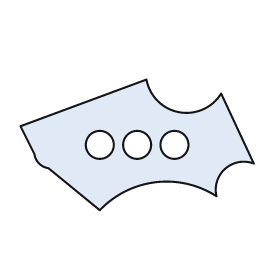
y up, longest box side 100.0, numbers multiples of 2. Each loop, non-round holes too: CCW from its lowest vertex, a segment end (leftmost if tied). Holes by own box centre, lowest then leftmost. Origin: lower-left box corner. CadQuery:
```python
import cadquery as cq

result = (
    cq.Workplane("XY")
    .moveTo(34.0, 0.0)
    .threePointArc((58.0, 12.0), (84.0, 6.0))
    .threePointArc((88.0, 18.0), (100.0, 20.0))
    .lineTo(86.0, 50.0)
    .threePointArc((68.0, 42.0), (54.0, 56.0))
    .lineTo(0.0, 36.0)
    .lineTo(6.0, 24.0)
    .threePointArc((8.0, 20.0), (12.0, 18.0))
    .close()
    .moveTo(34.0, 28.0)
    .circle(6.0)
    .moveTo(50.0, 28.0)
    .circle(6.0)
    .moveTo(66.0, 28.0)
    .circle(6.0)
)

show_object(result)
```